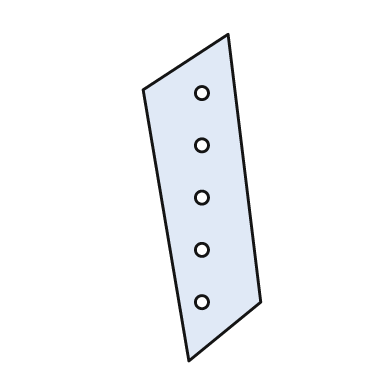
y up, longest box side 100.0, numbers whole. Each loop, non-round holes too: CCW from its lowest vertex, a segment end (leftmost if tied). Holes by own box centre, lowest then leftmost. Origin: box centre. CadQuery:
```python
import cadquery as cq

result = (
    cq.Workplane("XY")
    .moveTo(-4.0, -50.0)
    .lineTo(18.0, -32.0)
    .lineTo(8.0, 50.0)
    .lineTo(-18.0, 33.0)
    .close()
    .moveTo(0.0, -32.0)
    .circle(2.0)
    .moveTo(0.0, -16.0)
    .circle(2.0)
    .moveTo(0.0, 0.0)
    .circle(2.0)
    .moveTo(0.0, 16.0)
    .circle(2.0)
    .moveTo(0.0, 32.0)
    .circle(2.0)
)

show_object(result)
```